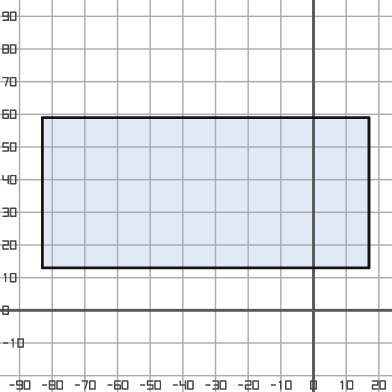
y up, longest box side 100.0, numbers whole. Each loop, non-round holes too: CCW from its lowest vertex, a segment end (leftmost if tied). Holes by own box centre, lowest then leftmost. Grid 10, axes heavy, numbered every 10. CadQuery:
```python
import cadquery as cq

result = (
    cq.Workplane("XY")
    .moveTo(-83.0, 13.0)
    .lineTo(17.0, 13.0)
    .lineTo(17.0, 59.0)
    .lineTo(-83.0, 59.0)
    .close()
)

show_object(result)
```